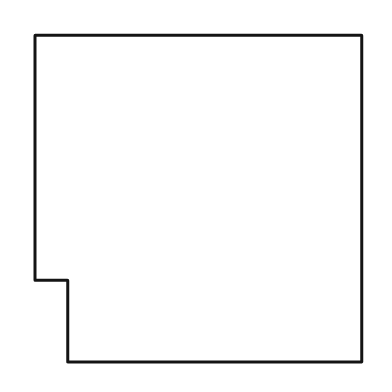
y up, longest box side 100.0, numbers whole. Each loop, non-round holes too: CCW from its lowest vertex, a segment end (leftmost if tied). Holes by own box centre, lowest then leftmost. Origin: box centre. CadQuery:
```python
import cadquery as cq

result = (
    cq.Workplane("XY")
    .moveTo(-40.0, -50.0)
    .lineTo(50.0, -50.0)
    .lineTo(50.0, 50.0)
    .lineTo(-50.0, 50.0)
    .lineTo(-50.0, -25.0)
    .lineTo(-40.0, -25.0)
    .close()
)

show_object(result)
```